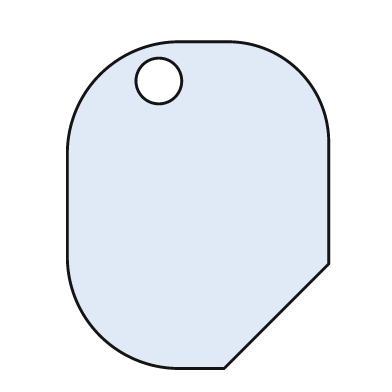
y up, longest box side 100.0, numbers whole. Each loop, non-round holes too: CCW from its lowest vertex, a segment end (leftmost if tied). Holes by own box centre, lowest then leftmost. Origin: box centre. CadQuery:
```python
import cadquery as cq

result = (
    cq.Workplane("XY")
    .moveTo(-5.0, -50.0)
    .lineTo(8.0, -50.0)
    .lineTo(40.0, -18.0)
    .lineTo(40.0, 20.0)
    .threePointArc((31.0, 41.0), (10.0, 50.0))
    .lineTo(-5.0, 50.0)
    .threePointArc((-30.0, 40.0), (-40.0, 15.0))
    .lineTo(-40.0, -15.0)
    .threePointArc((-30.0, -40.0), (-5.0, -50.0))
    .close()
    .moveTo(-12.0, 38.0)
    .circle(7.0)
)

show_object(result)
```